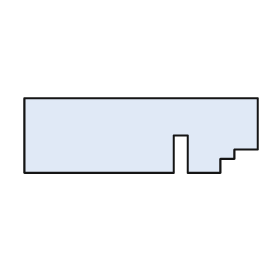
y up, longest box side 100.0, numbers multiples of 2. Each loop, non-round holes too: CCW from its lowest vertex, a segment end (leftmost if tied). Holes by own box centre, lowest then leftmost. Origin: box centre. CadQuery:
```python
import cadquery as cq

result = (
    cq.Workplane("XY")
    .moveTo(-50.0, -16.0)
    .lineTo(14.0, -16.0)
    .lineTo(14.0, 0.0)
    .lineTo(20.0, 0.0)
    .lineTo(20.0, -16.0)
    .lineTo(34.0, -16.0)
    .lineTo(34.0, -10.0)
    .lineTo(40.0, -10.0)
    .lineTo(40.0, -6.0)
    .lineTo(50.0, -6.0)
    .lineTo(50.0, 16.0)
    .lineTo(-50.0, 16.0)
    .close()
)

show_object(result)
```